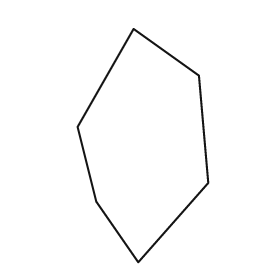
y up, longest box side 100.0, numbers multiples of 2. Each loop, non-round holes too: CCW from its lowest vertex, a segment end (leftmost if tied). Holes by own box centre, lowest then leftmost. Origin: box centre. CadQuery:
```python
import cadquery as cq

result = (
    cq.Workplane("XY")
    .moveTo(-2.0, -50.0)
    .lineTo(28.0, -16.0)
    .lineTo(24.0, 30.0)
    .lineTo(-4.0, 50.0)
    .lineTo(-28.0, 8.0)
    .lineTo(-20.0, -24.0)
    .close()
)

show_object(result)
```